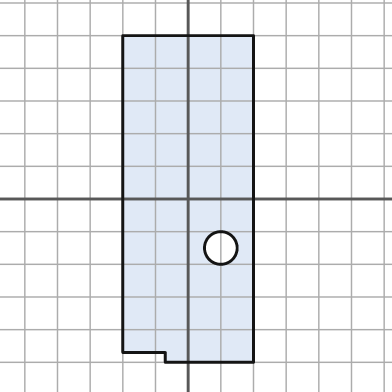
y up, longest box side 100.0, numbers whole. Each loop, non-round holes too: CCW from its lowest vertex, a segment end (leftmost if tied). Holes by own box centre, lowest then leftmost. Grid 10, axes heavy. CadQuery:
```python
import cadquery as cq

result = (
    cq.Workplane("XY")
    .moveTo(-7.0, -50.0)
    .lineTo(20.0, -50.0)
    .lineTo(20.0, 50.0)
    .lineTo(-20.0, 50.0)
    .lineTo(-20.0, -47.0)
    .lineTo(-7.0, -47.0)
    .close()
    .moveTo(10.0, -15.0)
    .circle(5.0)
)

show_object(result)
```